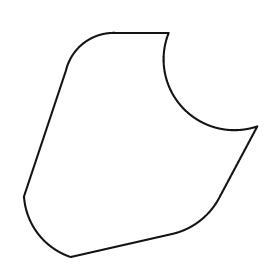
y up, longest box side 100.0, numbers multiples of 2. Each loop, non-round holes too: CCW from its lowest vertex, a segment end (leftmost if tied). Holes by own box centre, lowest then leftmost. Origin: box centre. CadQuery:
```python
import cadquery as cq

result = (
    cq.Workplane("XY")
    .moveTo(-30.0, -48.0)
    .lineTo(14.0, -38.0)
    .threePointArc((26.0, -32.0), (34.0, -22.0))
    .lineTo(50.0, 8.0)
    .threePointArc((18.0, 16.0), (12.0, 48.0))
    .lineTo(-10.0, 48.0)
    .threePointArc((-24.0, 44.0), (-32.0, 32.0))
    .lineTo(-50.0, -22.0)
    .threePointArc((-44.0, -38.0), (-30.0, -48.0))
    .close()
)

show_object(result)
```